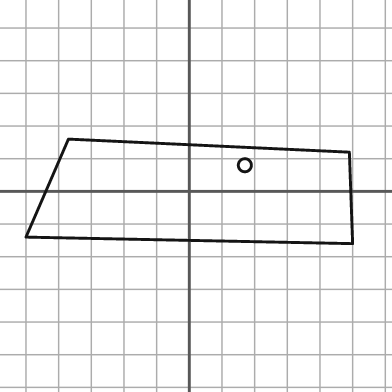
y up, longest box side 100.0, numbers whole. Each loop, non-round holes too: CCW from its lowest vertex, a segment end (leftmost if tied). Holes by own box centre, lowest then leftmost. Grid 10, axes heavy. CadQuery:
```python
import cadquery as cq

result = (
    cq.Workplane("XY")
    .moveTo(50.0, -16.0)
    .lineTo(49.0, 12.0)
    .lineTo(-37.0, 16.0)
    .lineTo(-50.0, -14.0)
    .close()
    .moveTo(17.0, 8.0)
    .circle(2.0)
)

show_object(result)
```